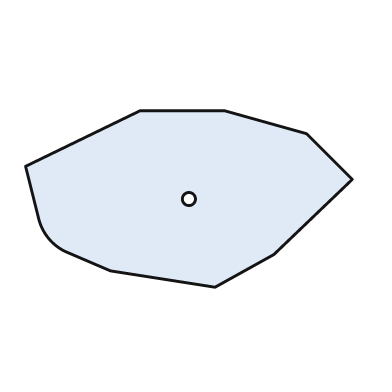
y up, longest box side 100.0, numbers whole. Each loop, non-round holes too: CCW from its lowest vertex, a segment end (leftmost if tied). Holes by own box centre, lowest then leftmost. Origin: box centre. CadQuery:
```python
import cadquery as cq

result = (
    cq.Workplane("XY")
    .moveTo(8.0, -27.0)
    .lineTo(26.0, -17.0)
    .lineTo(50.0, 6.0)
    .lineTo(36.0, 20.0)
    .lineTo(11.0, 27.0)
    .lineTo(-15.0, 27.0)
    .lineTo(-50.0, 10.0)
    .lineTo(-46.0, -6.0)
    .threePointArc((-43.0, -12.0), (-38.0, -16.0))
    .lineTo(-24.0, -22.0)
    .close()
    .moveTo(0.0, 0.0)
    .circle(2.0)
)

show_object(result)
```